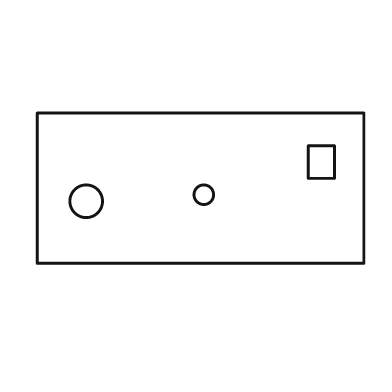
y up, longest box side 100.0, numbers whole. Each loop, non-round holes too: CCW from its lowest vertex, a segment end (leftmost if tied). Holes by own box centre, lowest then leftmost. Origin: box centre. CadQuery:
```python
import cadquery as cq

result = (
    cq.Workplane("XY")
    .moveTo(-50.0, -23.0)
    .lineTo(50.0, -23.0)
    .lineTo(50.0, 23.0)
    .lineTo(-50.0, 23.0)
    .close()
    .moveTo(-35.0, -4.0)
    .circle(5.0)
    .moveTo(1.0, -2.0)
    .circle(3.0)
    .moveTo(33.0, 3.0)
    .lineTo(41.0, 3.0)
    .lineTo(41.0, 13.0)
    .lineTo(33.0, 13.0)
    .close()
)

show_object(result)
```